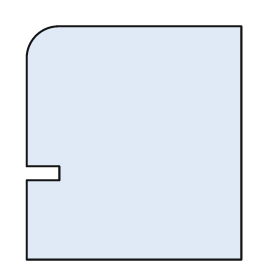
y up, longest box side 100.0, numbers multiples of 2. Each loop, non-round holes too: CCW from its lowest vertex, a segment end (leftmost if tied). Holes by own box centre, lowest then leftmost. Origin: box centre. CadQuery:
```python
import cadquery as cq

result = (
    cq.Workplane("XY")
    .moveTo(-46.0, -50.0)
    .lineTo(46.0, -50.0)
    .lineTo(46.0, 50.0)
    .lineTo(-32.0, 50.0)
    .threePointArc((-42.0, 46.0), (-46.0, 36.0))
    .lineTo(-46.0, -10.0)
    .lineTo(-32.0, -10.0)
    .lineTo(-32.0, -16.0)
    .lineTo(-46.0, -16.0)
    .close()
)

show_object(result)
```